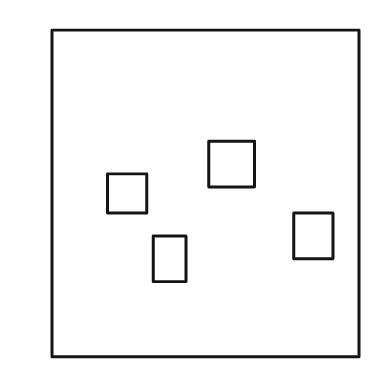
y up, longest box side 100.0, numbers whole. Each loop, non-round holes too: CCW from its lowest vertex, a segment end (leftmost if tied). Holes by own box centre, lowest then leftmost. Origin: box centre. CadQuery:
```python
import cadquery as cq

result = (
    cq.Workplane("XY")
    .moveTo(-47.0, -50.0)
    .lineTo(47.0, -50.0)
    .lineTo(47.0, 50.0)
    .lineTo(-47.0, 50.0)
    .close()
    .moveTo(-16.0, -27.0)
    .lineTo(-6.0, -27.0)
    .lineTo(-6.0, -13.0)
    .lineTo(-16.0, -13.0)
    .close()
    .moveTo(27.0, -20.0)
    .lineTo(39.0, -20.0)
    .lineTo(39.0, -6.0)
    .lineTo(27.0, -6.0)
    .close()
    .moveTo(-30.0, -6.0)
    .lineTo(-18.0, -6.0)
    .lineTo(-18.0, 6.0)
    .lineTo(-30.0, 6.0)
    .close()
    .moveTo(1.0, 2.0)
    .lineTo(15.0, 2.0)
    .lineTo(15.0, 16.0)
    .lineTo(1.0, 16.0)
    .close()
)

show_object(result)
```